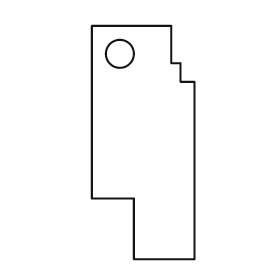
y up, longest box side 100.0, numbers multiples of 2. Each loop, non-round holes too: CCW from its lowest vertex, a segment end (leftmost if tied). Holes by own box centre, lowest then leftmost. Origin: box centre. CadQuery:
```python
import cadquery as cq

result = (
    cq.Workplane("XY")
    .moveTo(-4.0, -50.0)
    .lineTo(22.0, -50.0)
    .lineTo(22.0, 26.0)
    .lineTo(16.0, 26.0)
    .lineTo(16.0, 34.0)
    .lineTo(12.0, 34.0)
    .lineTo(12.0, 50.0)
    .lineTo(-22.0, 50.0)
    .lineTo(-22.0, -24.0)
    .lineTo(-4.0, -24.0)
    .close()
    .moveTo(-10.0, 38.0)
    .circle(6.0)
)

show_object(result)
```